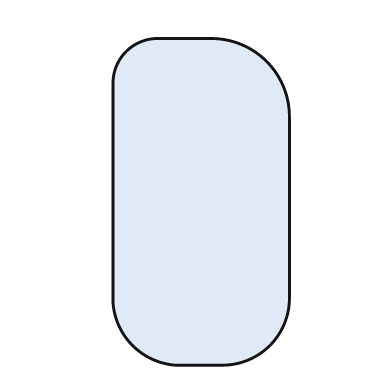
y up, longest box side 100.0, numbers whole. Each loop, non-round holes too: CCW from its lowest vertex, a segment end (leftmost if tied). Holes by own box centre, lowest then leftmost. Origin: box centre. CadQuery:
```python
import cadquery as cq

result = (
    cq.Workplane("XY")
    .moveTo(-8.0, -50.0)
    .lineTo(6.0, -50.0)
    .threePointArc((21.0, -44.0), (27.0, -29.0))
    .lineTo(27.0, 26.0)
    .threePointArc((20.0, 43.0), (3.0, 50.0))
    .lineTo(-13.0, 50.0)
    .threePointArc((-23.0, 46.0), (-27.0, 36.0))
    .lineTo(-27.0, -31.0)
    .threePointArc((-21.0, -44.0), (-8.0, -50.0))
    .close()
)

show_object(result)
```